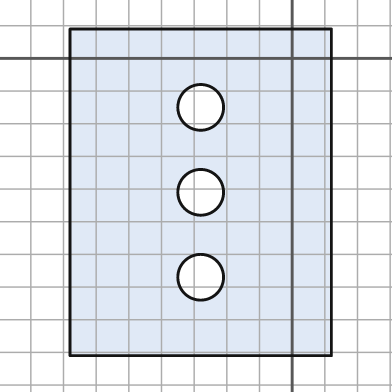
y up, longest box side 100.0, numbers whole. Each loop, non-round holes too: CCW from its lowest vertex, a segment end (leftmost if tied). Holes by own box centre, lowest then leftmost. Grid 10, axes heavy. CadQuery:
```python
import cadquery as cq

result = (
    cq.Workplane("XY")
    .moveTo(-68.0, -91.0)
    .lineTo(12.0, -91.0)
    .lineTo(12.0, 9.0)
    .lineTo(-68.0, 9.0)
    .close()
    .moveTo(-28.0, -67.0)
    .circle(7.0)
    .moveTo(-28.0, -41.0)
    .circle(7.0)
    .moveTo(-28.0, -15.0)
    .circle(7.0)
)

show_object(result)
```